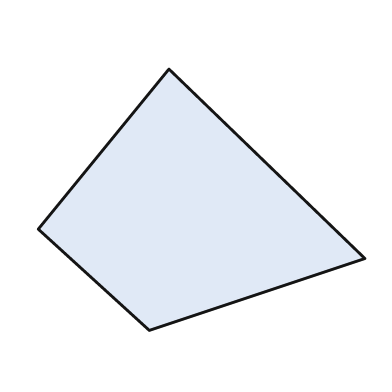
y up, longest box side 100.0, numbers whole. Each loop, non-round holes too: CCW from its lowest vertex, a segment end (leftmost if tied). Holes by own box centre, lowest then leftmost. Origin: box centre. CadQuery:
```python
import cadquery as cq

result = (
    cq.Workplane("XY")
    .moveTo(-16.0, -40.0)
    .lineTo(50.0, -18.0)
    .lineTo(-10.0, 40.0)
    .lineTo(-50.0, -9.0)
    .close()
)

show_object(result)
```